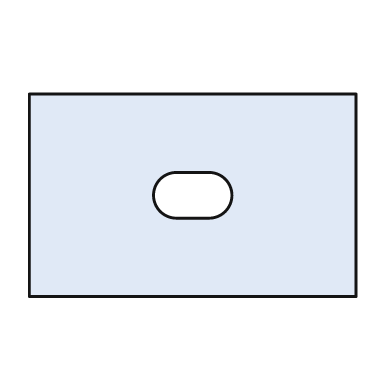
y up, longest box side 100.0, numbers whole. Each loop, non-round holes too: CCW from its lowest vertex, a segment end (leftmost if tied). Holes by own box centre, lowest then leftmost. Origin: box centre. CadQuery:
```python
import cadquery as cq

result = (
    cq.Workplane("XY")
    .moveTo(-50.0, -31.0)
    .lineTo(50.0, -31.0)
    .lineTo(50.0, 31.0)
    .lineTo(-50.0, 31.0)
    .close()
    .moveTo(-5.0, -7.0)
    .lineTo(5.0, -7.0)
    .threePointArc((12.0, 0.0), (5.0, 7.0))
    .lineTo(-5.0, 7.0)
    .threePointArc((-12.0, 0.0), (-5.0, -7.0))
    .close()
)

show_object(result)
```